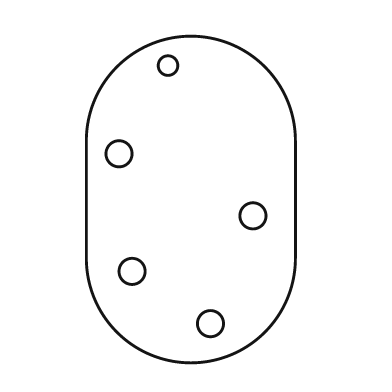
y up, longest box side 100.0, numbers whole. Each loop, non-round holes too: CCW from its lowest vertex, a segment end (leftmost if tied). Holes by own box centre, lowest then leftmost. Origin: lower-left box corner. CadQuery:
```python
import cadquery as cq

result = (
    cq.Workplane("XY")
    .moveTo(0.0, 32.0)
    .threePointArc((32.0, 0.0), (64.0, 32.0))
    .lineTo(64.0, 68.0)
    .threePointArc((32.0, 100.0), (0.0, 68.0))
    .close()
    .moveTo(38.0, 12.0)
    .circle(4.0)
    .moveTo(14.0, 28.0)
    .circle(4.0)
    .moveTo(51.0, 45.0)
    .circle(4.0)
    .moveTo(10.0, 64.0)
    .circle(4.0)
    .moveTo(25.0, 91.0)
    .circle(3.0)
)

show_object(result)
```